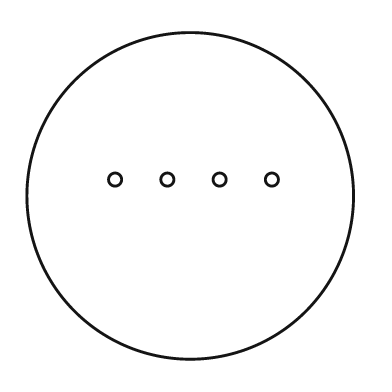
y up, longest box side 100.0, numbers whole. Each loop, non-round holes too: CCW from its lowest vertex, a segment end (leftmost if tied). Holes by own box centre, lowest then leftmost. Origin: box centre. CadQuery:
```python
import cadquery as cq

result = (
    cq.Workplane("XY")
    .moveTo(0.0, 0.0)
    .circle(50.0)
    .moveTo(-23.0, 5.0)
    .circle(2.0)
    .moveTo(-7.0, 5.0)
    .circle(2.0)
    .moveTo(9.0, 5.0)
    .circle(2.0)
    .moveTo(25.0, 5.0)
    .circle(2.0)
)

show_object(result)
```